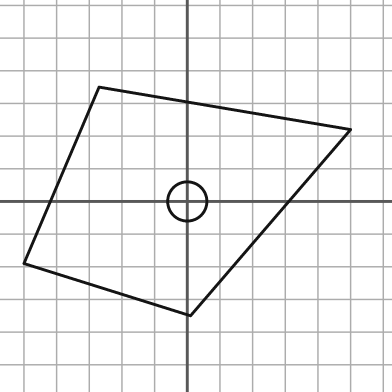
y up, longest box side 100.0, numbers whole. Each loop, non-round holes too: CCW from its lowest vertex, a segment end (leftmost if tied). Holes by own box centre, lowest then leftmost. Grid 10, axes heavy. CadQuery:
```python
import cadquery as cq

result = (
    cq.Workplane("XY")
    .moveTo(1.0, -35.0)
    .lineTo(50.0, 22.0)
    .lineTo(-27.0, 35.0)
    .lineTo(-50.0, -19.0)
    .close()
    .moveTo(0.0, 0.0)
    .circle(6.0)
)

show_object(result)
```